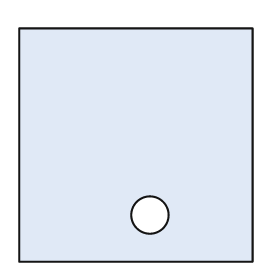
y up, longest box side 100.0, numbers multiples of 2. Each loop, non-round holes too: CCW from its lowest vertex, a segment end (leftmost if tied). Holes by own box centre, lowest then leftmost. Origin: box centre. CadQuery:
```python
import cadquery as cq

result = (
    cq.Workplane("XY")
    .moveTo(-50.0, -50.0)
    .lineTo(50.0, -50.0)
    .lineTo(50.0, 50.0)
    .lineTo(-50.0, 50.0)
    .close()
    .moveTo(6.0, -30.0)
    .circle(8.0)
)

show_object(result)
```